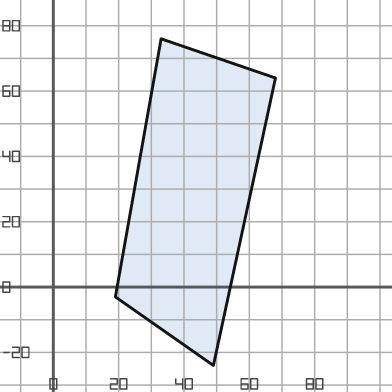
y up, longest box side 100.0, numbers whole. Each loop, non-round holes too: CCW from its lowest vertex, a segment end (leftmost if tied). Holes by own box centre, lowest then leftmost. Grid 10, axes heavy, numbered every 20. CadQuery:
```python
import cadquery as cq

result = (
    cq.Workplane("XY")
    .moveTo(49.0, -24.0)
    .lineTo(68.0, 64.0)
    .lineTo(33.0, 76.0)
    .lineTo(19.0, -3.0)
    .close()
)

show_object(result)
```